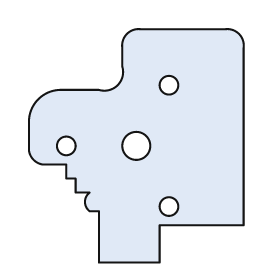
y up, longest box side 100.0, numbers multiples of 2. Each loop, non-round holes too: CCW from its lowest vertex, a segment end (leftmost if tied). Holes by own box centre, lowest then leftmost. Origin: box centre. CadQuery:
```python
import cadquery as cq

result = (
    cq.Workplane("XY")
    .moveTo(-16.0, -50.0)
    .lineTo(10.0, -50.0)
    .lineTo(10.0, -34.0)
    .lineTo(46.0, -34.0)
    .lineTo(46.0, 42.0)
    .threePointArc((44.0, 48.0), (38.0, 50.0))
    .lineTo(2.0, 50.0)
    .threePointArc((-4.0, 48.0), (-6.0, 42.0))
    .lineTo(-6.0, 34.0)
    .threePointArc((-8.0, 26.0), (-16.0, 24.0))
    .lineTo(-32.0, 24.0)
    .threePointArc((-42.0, 20.0), (-46.0, 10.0))
    .lineTo(-46.0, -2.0)
    .threePointArc((-44.0, -6.0), (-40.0, -8.0))
    .lineTo(-30.0, -8.0)
    .lineTo(-30.0, -14.0)
    .lineTo(-26.0, -14.0)
    .lineTo(-26.0, -20.0)
    .lineTo(-20.0, -20.0)
    .threePointArc((-22.0, -24.0), (-20.0, -28.0))
    .lineTo(-16.0, -28.0)
    .close()
    .moveTo(14.0, -26.0)
    .circle(4.0)
    .moveTo(-30.0, 0.0)
    .circle(4.0)
    .moveTo(0.0, 0.0)
    .circle(6.0)
    .moveTo(14.0, 26.0)
    .circle(4.0)
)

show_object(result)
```